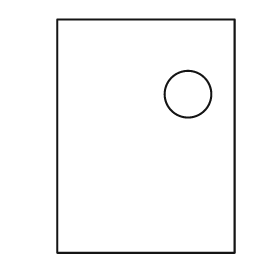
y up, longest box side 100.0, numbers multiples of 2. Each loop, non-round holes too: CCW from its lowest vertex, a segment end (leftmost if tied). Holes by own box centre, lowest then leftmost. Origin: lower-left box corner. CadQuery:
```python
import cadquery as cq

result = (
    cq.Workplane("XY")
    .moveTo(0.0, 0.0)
    .lineTo(76.0, 0.0)
    .lineTo(76.0, 100.0)
    .lineTo(0.0, 100.0)
    .close()
    .moveTo(56.0, 68.0)
    .circle(10.0)
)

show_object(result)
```